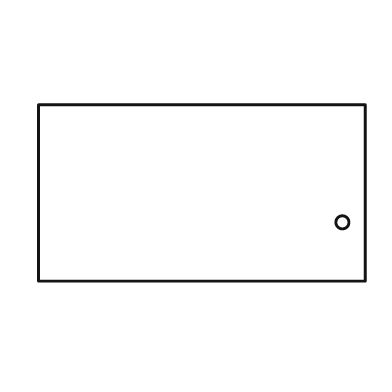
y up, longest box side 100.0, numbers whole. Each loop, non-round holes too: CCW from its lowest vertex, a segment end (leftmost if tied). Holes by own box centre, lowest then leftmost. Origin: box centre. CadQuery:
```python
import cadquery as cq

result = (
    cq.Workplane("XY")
    .moveTo(-50.0, -27.0)
    .lineTo(50.0, -27.0)
    .lineTo(50.0, 27.0)
    .lineTo(-50.0, 27.0)
    .close()
    .moveTo(43.0, -9.0)
    .circle(2.0)
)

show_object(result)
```